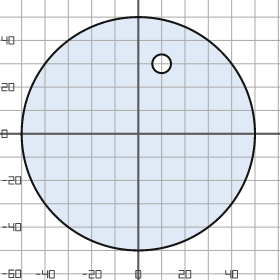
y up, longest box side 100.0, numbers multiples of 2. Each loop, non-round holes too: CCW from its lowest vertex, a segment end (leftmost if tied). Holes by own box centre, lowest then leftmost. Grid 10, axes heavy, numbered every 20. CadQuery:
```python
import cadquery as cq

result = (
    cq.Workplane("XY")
    .moveTo(0.0, 0.0)
    .circle(50.0)
    .moveTo(10.0, 30.0)
    .circle(4.0)
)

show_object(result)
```